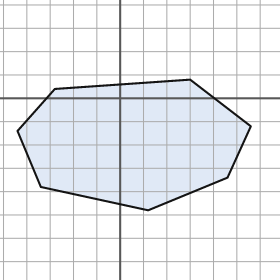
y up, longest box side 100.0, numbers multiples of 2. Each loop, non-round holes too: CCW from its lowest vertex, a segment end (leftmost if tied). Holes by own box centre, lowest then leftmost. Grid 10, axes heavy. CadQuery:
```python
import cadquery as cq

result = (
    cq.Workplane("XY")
    .moveTo(12.0, -48.0)
    .lineTo(46.0, -34.0)
    .lineTo(56.0, -12.0)
    .lineTo(30.0, 8.0)
    .lineTo(-28.0, 4.0)
    .lineTo(-44.0, -14.0)
    .lineTo(-34.0, -38.0)
    .close()
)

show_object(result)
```